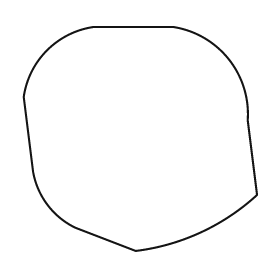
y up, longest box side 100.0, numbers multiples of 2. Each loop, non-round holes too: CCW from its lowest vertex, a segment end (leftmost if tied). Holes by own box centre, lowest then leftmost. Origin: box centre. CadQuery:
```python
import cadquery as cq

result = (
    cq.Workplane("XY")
    .moveTo(-2.0, -48.0)
    .threePointArc((26.0, -40.0), (50.0, -24.0))
    .lineTo(46.0, 8.0)
    .threePointArc((38.0, 34.0), (14.0, 48.0))
    .lineTo(-20.0, 48.0)
    .threePointArc((-40.0, 38.0), (-50.0, 18.0))
    .lineTo(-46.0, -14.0)
    .threePointArc((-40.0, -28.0), (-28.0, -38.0))
    .close()
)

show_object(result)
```